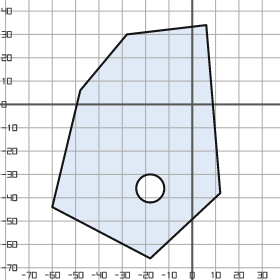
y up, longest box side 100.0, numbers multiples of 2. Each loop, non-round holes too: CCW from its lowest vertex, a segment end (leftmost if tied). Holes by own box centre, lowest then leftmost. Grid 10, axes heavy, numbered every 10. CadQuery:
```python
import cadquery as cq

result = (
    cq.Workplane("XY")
    .moveTo(-18.0, -66.0)
    .lineTo(12.0, -38.0)
    .lineTo(6.0, 34.0)
    .lineTo(-28.0, 30.0)
    .lineTo(-48.0, 6.0)
    .lineTo(-60.0, -44.0)
    .close()
    .moveTo(-18.0, -36.0)
    .circle(6.0)
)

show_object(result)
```